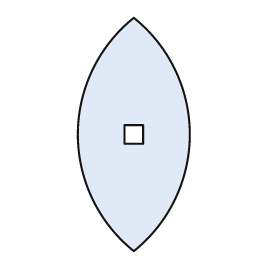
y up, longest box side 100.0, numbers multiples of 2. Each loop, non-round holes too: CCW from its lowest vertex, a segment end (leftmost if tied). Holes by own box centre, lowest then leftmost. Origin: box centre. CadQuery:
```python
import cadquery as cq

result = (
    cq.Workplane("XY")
    .moveTo(0.0, -50.0)
    .threePointArc((24.0, 0.0), (0.0, 50.0))
    .threePointArc((-24.0, 0.0), (0.0, -50.0))
    .close()
    .moveTo(-4.0, -4.0)
    .lineTo(4.0, -4.0)
    .lineTo(4.0, 4.0)
    .lineTo(-4.0, 4.0)
    .close()
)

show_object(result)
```